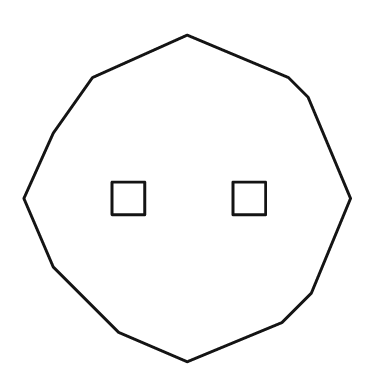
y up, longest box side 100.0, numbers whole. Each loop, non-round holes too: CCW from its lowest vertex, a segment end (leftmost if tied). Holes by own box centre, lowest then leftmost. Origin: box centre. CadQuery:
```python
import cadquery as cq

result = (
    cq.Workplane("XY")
    .moveTo(0.0, -50.0)
    .lineTo(29.0, -38.0)
    .lineTo(38.0, -29.0)
    .lineTo(50.0, 0.0)
    .lineTo(37.0, 31.0)
    .lineTo(31.0, 37.0)
    .lineTo(0.0, 50.0)
    .lineTo(-29.0, 37.0)
    .lineTo(-41.0, 20.0)
    .lineTo(-50.0, 0.0)
    .lineTo(-41.0, -21.0)
    .lineTo(-21.0, -41.0)
    .close()
    .moveTo(-23.0, -5.0)
    .lineTo(-13.0, -5.0)
    .lineTo(-13.0, 5.0)
    .lineTo(-23.0, 5.0)
    .close()
    .moveTo(14.0, -5.0)
    .lineTo(24.0, -5.0)
    .lineTo(24.0, 5.0)
    .lineTo(14.0, 5.0)
    .close()
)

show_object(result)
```